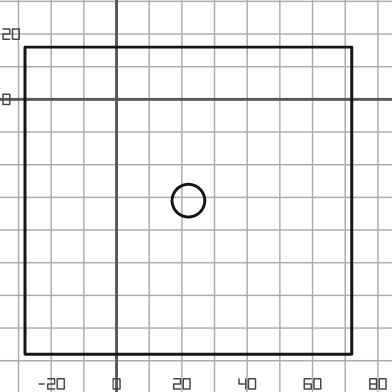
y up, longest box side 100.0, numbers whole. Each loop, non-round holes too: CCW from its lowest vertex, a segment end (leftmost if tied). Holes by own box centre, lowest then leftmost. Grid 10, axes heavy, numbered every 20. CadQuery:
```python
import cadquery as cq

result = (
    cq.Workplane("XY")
    .moveTo(-28.0, -78.0)
    .lineTo(72.0, -78.0)
    .lineTo(72.0, 16.0)
    .lineTo(-28.0, 16.0)
    .close()
    .moveTo(22.0, -31.0)
    .circle(5.0)
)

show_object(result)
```